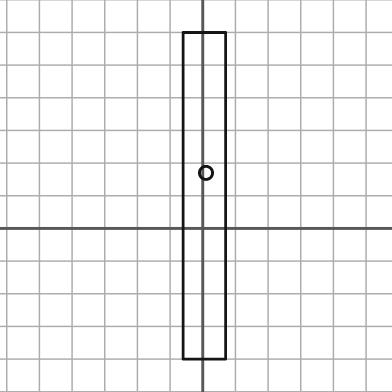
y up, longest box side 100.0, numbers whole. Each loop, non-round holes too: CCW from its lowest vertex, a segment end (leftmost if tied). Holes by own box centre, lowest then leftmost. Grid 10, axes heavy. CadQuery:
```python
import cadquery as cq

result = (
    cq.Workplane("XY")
    .moveTo(-6.0, -40.0)
    .lineTo(7.0, -40.0)
    .lineTo(7.0, 60.0)
    .lineTo(-6.0, 60.0)
    .close()
    .moveTo(1.0, 17.0)
    .circle(2.0)
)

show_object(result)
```